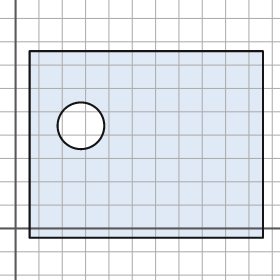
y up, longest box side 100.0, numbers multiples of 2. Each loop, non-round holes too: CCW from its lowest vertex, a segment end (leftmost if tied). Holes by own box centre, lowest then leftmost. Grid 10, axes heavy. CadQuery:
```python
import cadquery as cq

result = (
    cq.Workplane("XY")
    .moveTo(6.0, -4.0)
    .lineTo(106.0, -4.0)
    .lineTo(106.0, 76.0)
    .lineTo(6.0, 76.0)
    .close()
    .moveTo(28.0, 44.0)
    .circle(10.0)
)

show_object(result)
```